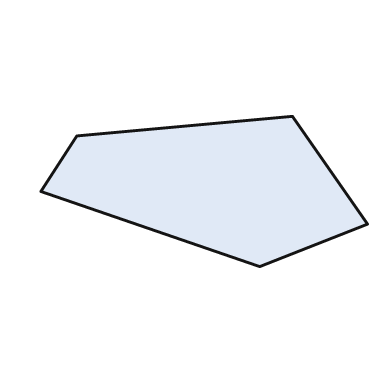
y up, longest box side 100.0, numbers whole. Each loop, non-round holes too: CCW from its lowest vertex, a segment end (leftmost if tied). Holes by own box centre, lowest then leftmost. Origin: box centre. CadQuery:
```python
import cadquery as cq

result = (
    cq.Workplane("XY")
    .moveTo(17.0, -23.0)
    .lineTo(50.0, -10.0)
    .lineTo(27.0, 23.0)
    .lineTo(-39.0, 17.0)
    .lineTo(-50.0, 0.0)
    .close()
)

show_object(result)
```